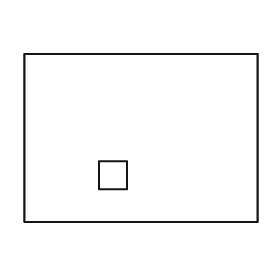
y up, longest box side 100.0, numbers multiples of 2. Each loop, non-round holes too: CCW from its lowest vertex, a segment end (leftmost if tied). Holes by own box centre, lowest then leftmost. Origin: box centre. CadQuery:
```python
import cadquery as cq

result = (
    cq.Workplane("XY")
    .moveTo(-50.0, -36.0)
    .lineTo(50.0, -36.0)
    .lineTo(50.0, 36.0)
    .lineTo(-50.0, 36.0)
    .close()
    .moveTo(-18.0, -22.0)
    .lineTo(-6.0, -22.0)
    .lineTo(-6.0, -10.0)
    .lineTo(-18.0, -10.0)
    .close()
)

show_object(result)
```